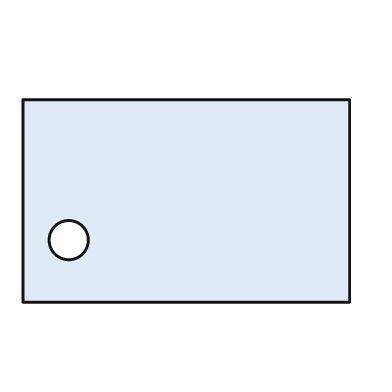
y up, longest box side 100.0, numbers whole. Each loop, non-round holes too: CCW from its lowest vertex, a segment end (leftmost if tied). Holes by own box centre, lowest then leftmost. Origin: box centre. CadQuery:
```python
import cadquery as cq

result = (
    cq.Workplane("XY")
    .moveTo(-50.0, -31.0)
    .lineTo(50.0, -31.0)
    .lineTo(50.0, 31.0)
    .lineTo(-50.0, 31.0)
    .close()
    .moveTo(-36.0, -12.0)
    .circle(6.0)
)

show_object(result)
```